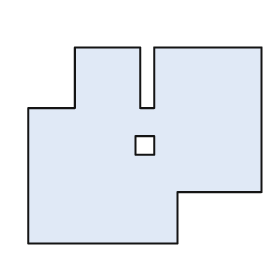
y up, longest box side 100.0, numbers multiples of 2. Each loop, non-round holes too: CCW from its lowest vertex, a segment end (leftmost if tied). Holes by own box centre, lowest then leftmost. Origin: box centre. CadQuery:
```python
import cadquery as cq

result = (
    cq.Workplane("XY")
    .moveTo(-50.0, -42.0)
    .lineTo(14.0, -42.0)
    .lineTo(14.0, -20.0)
    .lineTo(50.0, -20.0)
    .lineTo(50.0, 42.0)
    .lineTo(4.0, 42.0)
    .lineTo(4.0, 16.0)
    .lineTo(-2.0, 16.0)
    .lineTo(-2.0, 42.0)
    .lineTo(-30.0, 42.0)
    .lineTo(-30.0, 16.0)
    .lineTo(-50.0, 16.0)
    .close()
    .moveTo(-4.0, -4.0)
    .lineTo(4.0, -4.0)
    .lineTo(4.0, 4.0)
    .lineTo(-4.0, 4.0)
    .close()
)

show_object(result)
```